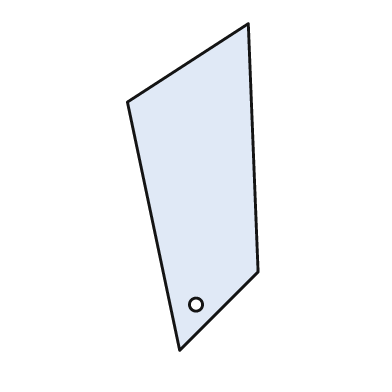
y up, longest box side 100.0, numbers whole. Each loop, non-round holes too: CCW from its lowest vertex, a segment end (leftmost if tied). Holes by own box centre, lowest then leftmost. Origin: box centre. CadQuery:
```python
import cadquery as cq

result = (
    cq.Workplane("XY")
    .moveTo(-4.0, -50.0)
    .lineTo(20.0, -26.0)
    .lineTo(17.0, 50.0)
    .lineTo(-20.0, 26.0)
    .close()
    .moveTo(1.0, -36.0)
    .circle(2.0)
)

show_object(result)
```